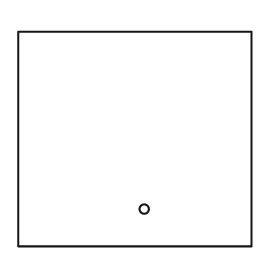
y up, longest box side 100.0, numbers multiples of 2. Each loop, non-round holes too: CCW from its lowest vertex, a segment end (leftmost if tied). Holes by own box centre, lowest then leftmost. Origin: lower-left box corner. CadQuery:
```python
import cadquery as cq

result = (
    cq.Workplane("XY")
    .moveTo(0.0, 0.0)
    .lineTo(100.0, 0.0)
    .lineTo(100.0, 92.0)
    .lineTo(0.0, 92.0)
    .close()
    .moveTo(54.0, 16.0)
    .circle(2.0)
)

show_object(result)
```